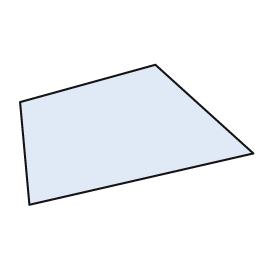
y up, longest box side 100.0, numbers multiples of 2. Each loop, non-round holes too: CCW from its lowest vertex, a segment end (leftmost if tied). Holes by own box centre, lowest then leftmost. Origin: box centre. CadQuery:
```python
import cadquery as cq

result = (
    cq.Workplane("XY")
    .moveTo(-46.0, -30.0)
    .lineTo(50.0, -8.0)
    .lineTo(8.0, 30.0)
    .lineTo(-50.0, 14.0)
    .close()
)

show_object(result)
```